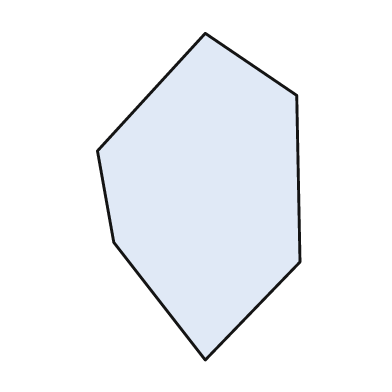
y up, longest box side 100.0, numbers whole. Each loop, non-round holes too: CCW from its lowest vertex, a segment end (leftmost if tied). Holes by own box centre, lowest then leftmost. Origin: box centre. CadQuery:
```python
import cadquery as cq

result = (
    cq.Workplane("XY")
    .moveTo(2.0, -50.0)
    .lineTo(31.0, -20.0)
    .lineTo(30.0, 31.0)
    .lineTo(2.0, 50.0)
    .lineTo(-31.0, 14.0)
    .lineTo(-26.0, -14.0)
    .close()
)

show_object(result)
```